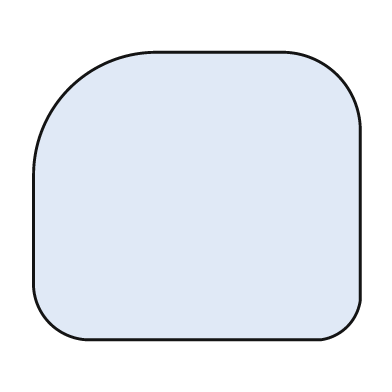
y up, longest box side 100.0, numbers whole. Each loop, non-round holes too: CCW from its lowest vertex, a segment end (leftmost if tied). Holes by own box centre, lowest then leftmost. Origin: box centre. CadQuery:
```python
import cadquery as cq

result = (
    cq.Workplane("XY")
    .moveTo(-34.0, -44.0)
    .lineTo(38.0, -44.0)
    .threePointArc((46.0, -40.0), (50.0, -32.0))
    .lineTo(50.0, 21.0)
    .threePointArc((43.0, 37.0), (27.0, 44.0))
    .lineTo(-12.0, 44.0)
    .threePointArc((-39.0, 33.0), (-50.0, 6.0))
    .lineTo(-50.0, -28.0)
    .threePointArc((-45.0, -39.0), (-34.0, -44.0))
    .close()
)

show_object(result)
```